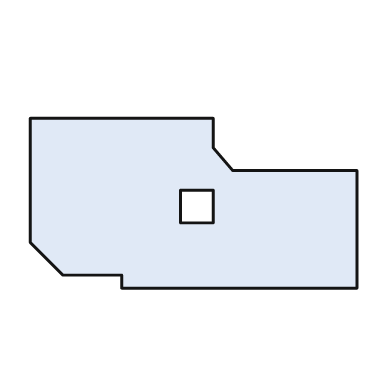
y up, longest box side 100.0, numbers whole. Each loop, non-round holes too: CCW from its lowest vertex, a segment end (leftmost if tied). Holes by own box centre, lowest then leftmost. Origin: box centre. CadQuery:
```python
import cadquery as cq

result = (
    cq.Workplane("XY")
    .moveTo(-22.0, -26.0)
    .lineTo(50.0, -26.0)
    .lineTo(50.0, 10.0)
    .lineTo(12.0, 10.0)
    .lineTo(6.0, 17.0)
    .lineTo(6.0, 26.0)
    .lineTo(-50.0, 26.0)
    .lineTo(-50.0, -12.0)
    .lineTo(-40.0, -22.0)
    .lineTo(-22.0, -22.0)
    .close()
    .moveTo(-4.0, -6.0)
    .lineTo(6.0, -6.0)
    .lineTo(6.0, 4.0)
    .lineTo(-4.0, 4.0)
    .close()
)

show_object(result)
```